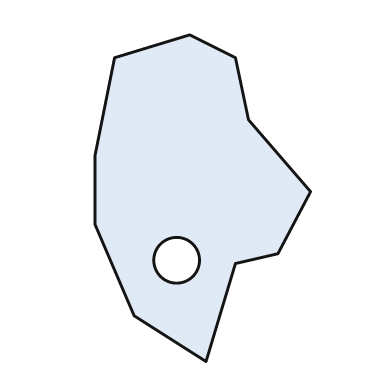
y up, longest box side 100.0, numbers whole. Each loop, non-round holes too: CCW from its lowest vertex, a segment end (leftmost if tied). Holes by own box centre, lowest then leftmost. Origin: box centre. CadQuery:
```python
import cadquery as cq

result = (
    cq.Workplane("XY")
    .moveTo(1.0, -50.0)
    .lineTo(10.0, -20.0)
    .lineTo(23.0, -17.0)
    .lineTo(33.0, 2.0)
    .lineTo(14.0, 24.0)
    .lineTo(10.0, 43.0)
    .lineTo(-4.0, 50.0)
    .lineTo(-27.0, 43.0)
    .lineTo(-33.0, 13.0)
    .lineTo(-33.0, -8.0)
    .lineTo(-21.0, -36.0)
    .close()
    .moveTo(-8.0, -19.0)
    .circle(7.0)
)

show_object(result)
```